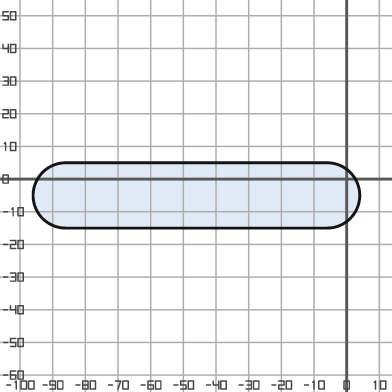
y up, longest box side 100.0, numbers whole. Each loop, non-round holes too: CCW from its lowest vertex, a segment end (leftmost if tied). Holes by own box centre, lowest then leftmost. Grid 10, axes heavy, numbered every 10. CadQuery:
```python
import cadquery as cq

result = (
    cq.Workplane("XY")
    .moveTo(-86.0, -15.0)
    .lineTo(-6.0, -15.0)
    .threePointArc((4.0, -5.0), (-6.0, 5.0))
    .lineTo(-86.0, 5.0)
    .threePointArc((-96.0, -5.0), (-86.0, -15.0))
    .close()
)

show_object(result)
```